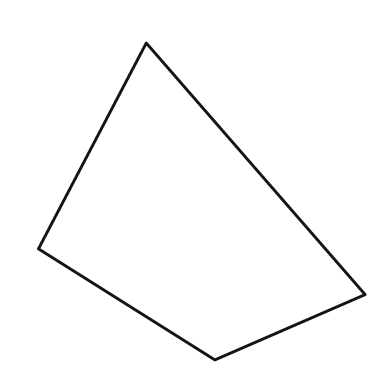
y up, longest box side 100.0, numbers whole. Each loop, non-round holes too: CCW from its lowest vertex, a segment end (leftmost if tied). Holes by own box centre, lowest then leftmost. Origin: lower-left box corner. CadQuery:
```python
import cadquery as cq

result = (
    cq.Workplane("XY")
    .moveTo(54.0, 0.0)
    .lineTo(100.0, 20.0)
    .lineTo(33.0, 97.0)
    .lineTo(0.0, 34.0)
    .close()
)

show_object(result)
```